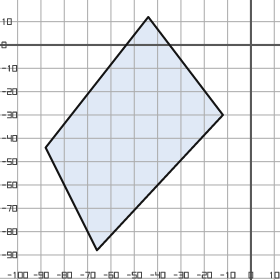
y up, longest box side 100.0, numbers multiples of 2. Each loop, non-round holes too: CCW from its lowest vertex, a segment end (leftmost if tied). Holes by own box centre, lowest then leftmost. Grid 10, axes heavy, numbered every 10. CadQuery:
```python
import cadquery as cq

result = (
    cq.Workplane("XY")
    .moveTo(-66.0, -88.0)
    .lineTo(-12.0, -30.0)
    .lineTo(-44.0, 12.0)
    .lineTo(-88.0, -44.0)
    .close()
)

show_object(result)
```